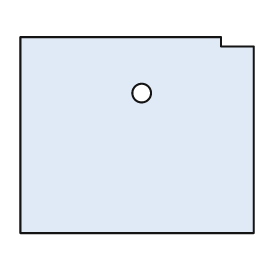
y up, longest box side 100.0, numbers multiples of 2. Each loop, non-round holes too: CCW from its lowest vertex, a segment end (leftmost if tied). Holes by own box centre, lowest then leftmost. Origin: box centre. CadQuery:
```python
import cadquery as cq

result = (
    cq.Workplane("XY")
    .moveTo(-50.0, -42.0)
    .lineTo(50.0, -42.0)
    .lineTo(50.0, 38.0)
    .lineTo(36.0, 38.0)
    .lineTo(36.0, 42.0)
    .lineTo(-50.0, 42.0)
    .close()
    .moveTo(2.0, 18.0)
    .circle(4.0)
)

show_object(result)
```